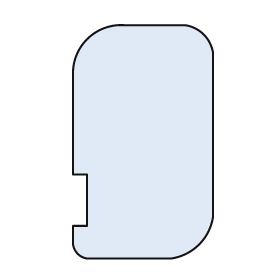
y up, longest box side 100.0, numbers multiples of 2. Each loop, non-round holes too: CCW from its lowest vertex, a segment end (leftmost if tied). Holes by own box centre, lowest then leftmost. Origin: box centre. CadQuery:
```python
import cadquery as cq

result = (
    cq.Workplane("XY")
    .moveTo(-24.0, -50.0)
    .lineTo(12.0, -50.0)
    .threePointArc((24.0, -44.0), (30.0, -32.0))
    .lineTo(30.0, 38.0)
    .threePointArc((26.0, 46.0), (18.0, 50.0))
    .lineTo(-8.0, 50.0)
    .threePointArc((-24.0, 44.0), (-30.0, 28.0))
    .lineTo(-30.0, -14.0)
    .lineTo(-24.0, -14.0)
    .lineTo(-24.0, -36.0)
    .lineTo(-30.0, -36.0)
    .lineTo(-30.0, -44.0)
    .threePointArc((-28.0, -48.0), (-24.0, -50.0))
    .close()
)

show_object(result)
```